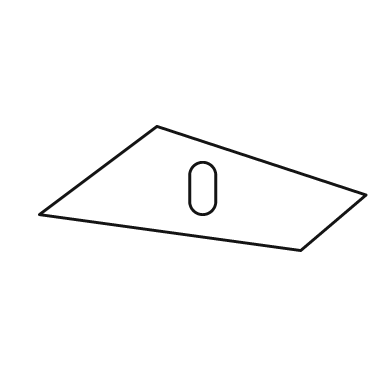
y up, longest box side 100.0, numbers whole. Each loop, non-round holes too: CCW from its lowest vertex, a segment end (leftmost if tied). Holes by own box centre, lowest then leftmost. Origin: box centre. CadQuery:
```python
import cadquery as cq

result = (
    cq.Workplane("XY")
    .moveTo(30.0, -19.0)
    .lineTo(50.0, -2.0)
    .lineTo(-14.0, 19.0)
    .lineTo(-50.0, -8.0)
    .close()
    .moveTo(-4.0, -4.0)
    .threePointArc((0.0, -8.0), (4.0, -4.0))
    .lineTo(4.0, 4.0)
    .threePointArc((0.0, 8.0), (-4.0, 4.0))
    .close()
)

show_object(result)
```